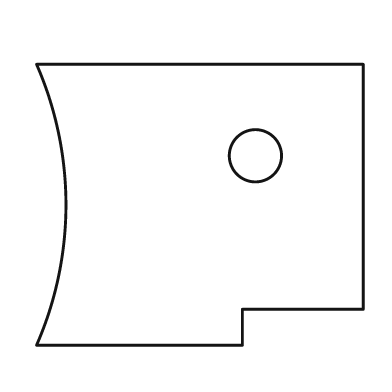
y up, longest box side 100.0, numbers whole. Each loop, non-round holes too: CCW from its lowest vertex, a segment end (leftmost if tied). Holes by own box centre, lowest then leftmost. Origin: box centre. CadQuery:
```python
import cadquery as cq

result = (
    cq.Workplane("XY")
    .moveTo(-50.0, -43.0)
    .lineTo(13.0, -43.0)
    .lineTo(13.0, -32.0)
    .lineTo(50.0, -32.0)
    .lineTo(50.0, 43.0)
    .lineTo(-50.0, 43.0)
    .threePointArc((-41.0, 0.0), (-50.0, -43.0))
    .close()
    .moveTo(17.0, 15.0)
    .circle(8.0)
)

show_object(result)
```